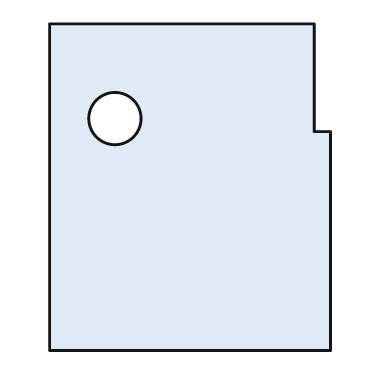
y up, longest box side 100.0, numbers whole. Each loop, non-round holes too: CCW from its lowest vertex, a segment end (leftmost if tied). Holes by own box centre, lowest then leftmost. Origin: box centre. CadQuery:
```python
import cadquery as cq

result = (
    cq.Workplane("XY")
    .moveTo(-43.0, -50.0)
    .lineTo(43.0, -50.0)
    .lineTo(43.0, 17.0)
    .lineTo(38.0, 17.0)
    .lineTo(38.0, 50.0)
    .lineTo(-43.0, 50.0)
    .close()
    .moveTo(-23.0, 21.0)
    .circle(8.0)
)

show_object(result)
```